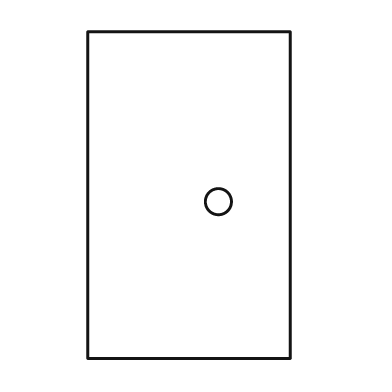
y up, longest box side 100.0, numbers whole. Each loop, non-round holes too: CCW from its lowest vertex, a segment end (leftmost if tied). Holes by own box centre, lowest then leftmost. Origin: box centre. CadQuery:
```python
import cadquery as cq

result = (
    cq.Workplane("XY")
    .moveTo(-31.0, -50.0)
    .lineTo(31.0, -50.0)
    .lineTo(31.0, 50.0)
    .lineTo(-31.0, 50.0)
    .close()
    .moveTo(9.0, -2.0)
    .circle(4.0)
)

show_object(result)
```